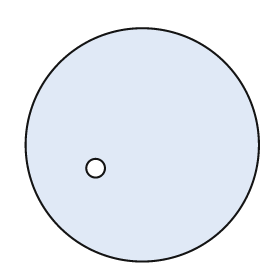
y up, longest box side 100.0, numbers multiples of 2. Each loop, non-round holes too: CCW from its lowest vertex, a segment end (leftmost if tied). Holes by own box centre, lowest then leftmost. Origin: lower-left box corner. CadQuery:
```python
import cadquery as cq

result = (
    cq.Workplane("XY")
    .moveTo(50.0, 50.0)
    .circle(50.0)
    .moveTo(30.0, 40.0)
    .circle(4.0)
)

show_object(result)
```